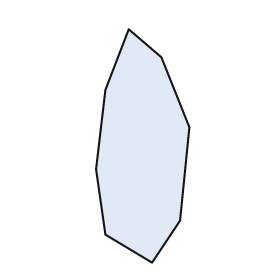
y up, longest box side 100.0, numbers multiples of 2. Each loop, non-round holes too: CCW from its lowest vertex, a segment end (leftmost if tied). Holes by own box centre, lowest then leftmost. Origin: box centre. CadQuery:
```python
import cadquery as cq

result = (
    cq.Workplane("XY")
    .moveTo(4.0, -50.0)
    .lineTo(16.0, -32.0)
    .lineTo(20.0, 8.0)
    .lineTo(8.0, 38.0)
    .lineTo(-6.0, 50.0)
    .lineTo(-16.0, 24.0)
    .lineTo(-20.0, -10.0)
    .lineTo(-16.0, -38.0)
    .close()
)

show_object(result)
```